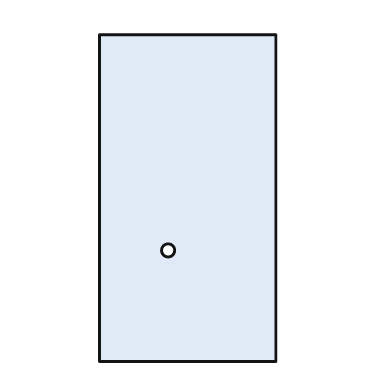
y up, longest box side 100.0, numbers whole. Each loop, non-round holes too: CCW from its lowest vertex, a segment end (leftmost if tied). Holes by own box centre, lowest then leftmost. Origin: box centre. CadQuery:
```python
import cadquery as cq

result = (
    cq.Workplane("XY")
    .moveTo(-27.0, -50.0)
    .lineTo(27.0, -50.0)
    .lineTo(27.0, 50.0)
    .lineTo(-27.0, 50.0)
    .close()
    .moveTo(-6.0, -16.0)
    .circle(2.0)
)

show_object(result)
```